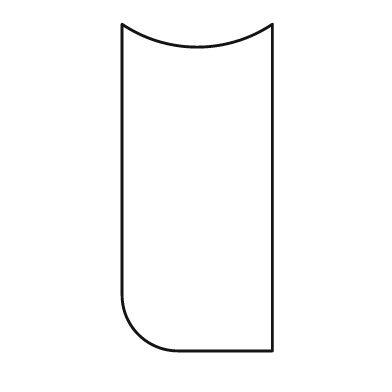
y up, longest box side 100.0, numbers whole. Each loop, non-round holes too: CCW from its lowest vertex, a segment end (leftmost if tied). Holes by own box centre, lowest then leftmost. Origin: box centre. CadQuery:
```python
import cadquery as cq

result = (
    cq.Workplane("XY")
    .moveTo(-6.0, -50.0)
    .lineTo(23.0, -50.0)
    .lineTo(23.0, 50.0)
    .threePointArc((0.0, 43.0), (-23.0, 50.0))
    .lineTo(-23.0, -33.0)
    .threePointArc((-18.0, -45.0), (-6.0, -50.0))
    .close()
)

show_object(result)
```